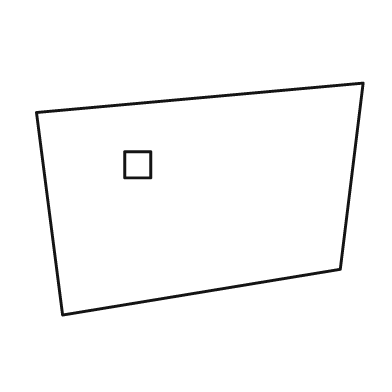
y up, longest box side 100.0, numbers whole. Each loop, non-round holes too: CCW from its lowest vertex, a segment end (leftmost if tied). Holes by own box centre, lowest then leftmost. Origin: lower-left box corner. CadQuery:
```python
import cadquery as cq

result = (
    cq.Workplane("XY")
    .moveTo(8.0, 0.0)
    .lineTo(93.0, 14.0)
    .lineTo(100.0, 71.0)
    .lineTo(0.0, 62.0)
    .close()
    .moveTo(27.0, 42.0)
    .lineTo(35.0, 42.0)
    .lineTo(35.0, 50.0)
    .lineTo(27.0, 50.0)
    .close()
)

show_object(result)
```